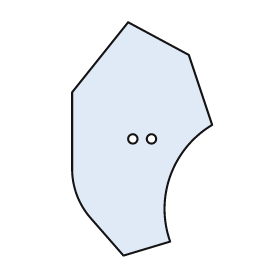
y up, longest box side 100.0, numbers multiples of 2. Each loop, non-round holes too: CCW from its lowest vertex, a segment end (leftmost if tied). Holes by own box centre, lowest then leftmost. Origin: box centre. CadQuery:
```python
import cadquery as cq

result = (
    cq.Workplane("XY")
    .moveTo(-8.0, -50.0)
    .lineTo(12.0, -44.0)
    .threePointArc((12.0, -16.0), (30.0, 6.0))
    .lineTo(20.0, 36.0)
    .lineTo(-6.0, 50.0)
    .lineTo(-30.0, 20.0)
    .lineTo(-30.0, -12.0)
    .threePointArc((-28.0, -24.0), (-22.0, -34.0))
    .close()
    .moveTo(-4.0, 0.0)
    .circle(2.0)
    .moveTo(4.0, 0.0)
    .circle(2.0)
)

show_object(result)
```